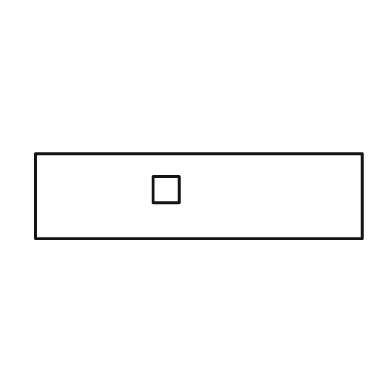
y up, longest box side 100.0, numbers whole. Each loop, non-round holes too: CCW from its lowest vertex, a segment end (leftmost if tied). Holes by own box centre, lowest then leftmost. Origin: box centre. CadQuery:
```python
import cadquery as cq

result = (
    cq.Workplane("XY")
    .moveTo(-50.0, -13.0)
    .lineTo(50.0, -13.0)
    .lineTo(50.0, 13.0)
    .lineTo(-50.0, 13.0)
    .close()
    .moveTo(-14.0, -2.0)
    .lineTo(-6.0, -2.0)
    .lineTo(-6.0, 6.0)
    .lineTo(-14.0, 6.0)
    .close()
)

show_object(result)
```